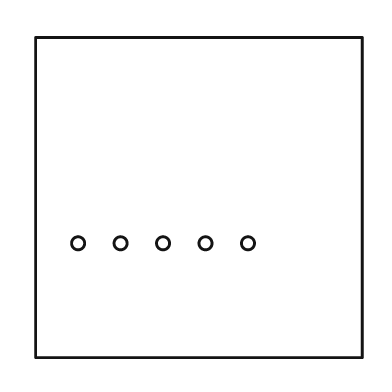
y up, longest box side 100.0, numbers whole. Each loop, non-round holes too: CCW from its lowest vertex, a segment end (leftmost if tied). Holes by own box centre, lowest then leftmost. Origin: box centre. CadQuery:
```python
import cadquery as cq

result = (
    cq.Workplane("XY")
    .moveTo(-50.0, -49.0)
    .lineTo(50.0, -49.0)
    .lineTo(50.0, 49.0)
    .lineTo(-50.0, 49.0)
    .close()
    .moveTo(-37.0, -14.0)
    .circle(2.0)
    .moveTo(-24.0, -14.0)
    .circle(2.0)
    .moveTo(-11.0, -14.0)
    .circle(2.0)
    .moveTo(2.0, -14.0)
    .circle(2.0)
    .moveTo(15.0, -14.0)
    .circle(2.0)
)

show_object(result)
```